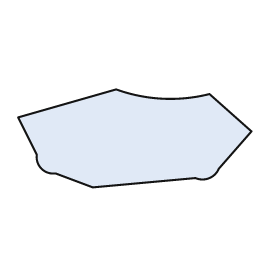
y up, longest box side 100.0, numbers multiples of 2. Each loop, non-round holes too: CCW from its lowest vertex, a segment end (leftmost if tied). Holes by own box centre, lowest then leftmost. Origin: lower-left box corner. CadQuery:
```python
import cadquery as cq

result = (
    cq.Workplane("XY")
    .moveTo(32.0, 0.0)
    .lineTo(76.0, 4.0)
    .threePointArc((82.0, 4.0), (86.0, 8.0))
    .lineTo(100.0, 24.0)
    .lineTo(82.0, 40.0)
    .threePointArc((62.0, 38.0), (42.0, 42.0))
    .lineTo(0.0, 30.0)
    .lineTo(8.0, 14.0)
    .threePointArc((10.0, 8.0), (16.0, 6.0))
    .close()
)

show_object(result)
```